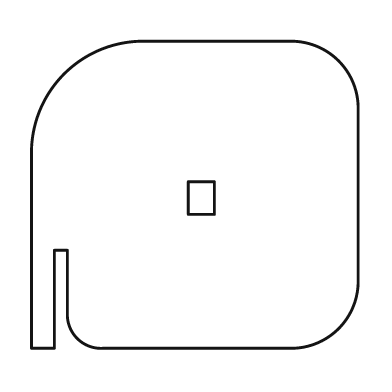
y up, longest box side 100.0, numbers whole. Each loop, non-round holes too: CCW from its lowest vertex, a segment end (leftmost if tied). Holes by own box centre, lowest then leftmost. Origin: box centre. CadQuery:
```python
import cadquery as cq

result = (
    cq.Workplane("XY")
    .moveTo(-50.0, -47.0)
    .lineTo(-43.0, -47.0)
    .lineTo(-43.0, -17.0)
    .lineTo(-39.0, -17.0)
    .lineTo(-39.0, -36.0)
    .threePointArc((-36.0, -44.0), (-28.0, -47.0))
    .lineTo(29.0, -47.0)
    .threePointArc((44.0, -41.0), (50.0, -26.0))
    .lineTo(50.0, 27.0)
    .threePointArc((44.0, 41.0), (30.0, 47.0))
    .lineTo(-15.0, 47.0)
    .threePointArc((-40.0, 37.0), (-50.0, 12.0))
    .close()
    .moveTo(-2.0, -6.0)
    .lineTo(6.0, -6.0)
    .lineTo(6.0, 4.0)
    .lineTo(-2.0, 4.0)
    .close()
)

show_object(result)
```